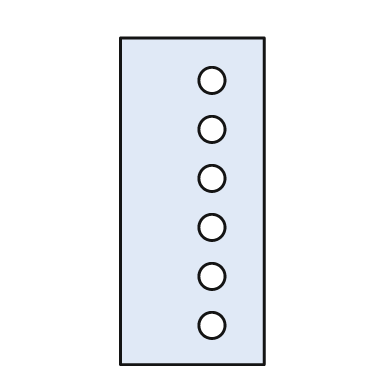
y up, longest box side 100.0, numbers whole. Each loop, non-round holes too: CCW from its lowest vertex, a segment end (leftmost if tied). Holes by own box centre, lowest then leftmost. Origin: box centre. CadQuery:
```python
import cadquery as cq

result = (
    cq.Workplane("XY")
    .moveTo(-22.0, -50.0)
    .lineTo(22.0, -50.0)
    .lineTo(22.0, 50.0)
    .lineTo(-22.0, 50.0)
    .close()
    .moveTo(6.0, -38.0)
    .circle(4.0)
    .moveTo(6.0, -23.0)
    .circle(4.0)
    .moveTo(6.0, -8.0)
    .circle(4.0)
    .moveTo(6.0, 7.0)
    .circle(4.0)
    .moveTo(6.0, 22.0)
    .circle(4.0)
    .moveTo(6.0, 37.0)
    .circle(4.0)
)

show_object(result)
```